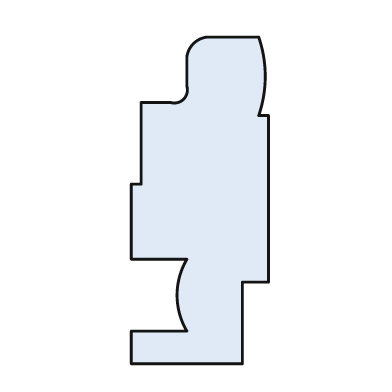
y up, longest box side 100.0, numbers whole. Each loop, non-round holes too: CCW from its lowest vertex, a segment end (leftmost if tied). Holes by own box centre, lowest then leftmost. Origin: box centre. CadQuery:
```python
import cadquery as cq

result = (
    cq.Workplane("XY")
    .moveTo(-21.0, -50.0)
    .lineTo(13.0, -50.0)
    .lineTo(13.0, -25.0)
    .lineTo(21.0, -25.0)
    .lineTo(21.0, 26.0)
    .lineTo(18.0, 26.0)
    .threePointArc((20.0, 38.0), (18.0, 50.0))
    .lineTo(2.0, 50.0)
    .threePointArc((-2.0, 48.0), (-4.0, 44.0))
    .lineTo(-4.0, 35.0)
    .threePointArc((-5.0, 31.0), (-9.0, 30.0))
    .lineTo(-18.0, 30.0)
    .lineTo(-18.0, 5.0)
    .lineTo(-21.0, 5.0)
    .lineTo(-21.0, -18.0)
    .lineTo(-4.0, -18.0)
    .threePointArc((-7.0, -29.0), (-4.0, -40.0))
    .lineTo(-21.0, -40.0)
    .close()
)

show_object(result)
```